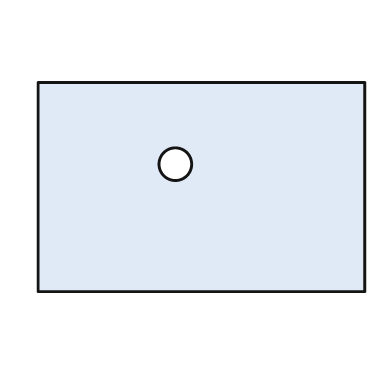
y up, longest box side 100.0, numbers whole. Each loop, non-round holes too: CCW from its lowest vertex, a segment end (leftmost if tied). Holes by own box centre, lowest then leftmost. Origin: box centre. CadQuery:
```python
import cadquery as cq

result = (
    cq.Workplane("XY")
    .moveTo(-50.0, -32.0)
    .lineTo(50.0, -32.0)
    .lineTo(50.0, 32.0)
    .lineTo(-50.0, 32.0)
    .close()
    .moveTo(-8.0, 7.0)
    .circle(5.0)
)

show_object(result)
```